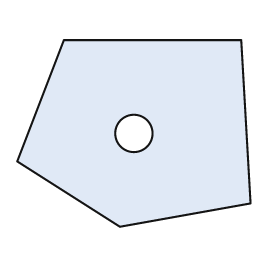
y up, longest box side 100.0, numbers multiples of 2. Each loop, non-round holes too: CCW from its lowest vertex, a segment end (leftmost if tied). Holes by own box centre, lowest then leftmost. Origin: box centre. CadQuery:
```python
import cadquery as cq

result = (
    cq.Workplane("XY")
    .moveTo(-6.0, -40.0)
    .lineTo(50.0, -30.0)
    .lineTo(46.0, 40.0)
    .lineTo(-30.0, 40.0)
    .lineTo(-50.0, -12.0)
    .close()
    .moveTo(0.0, 0.0)
    .circle(8.0)
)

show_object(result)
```